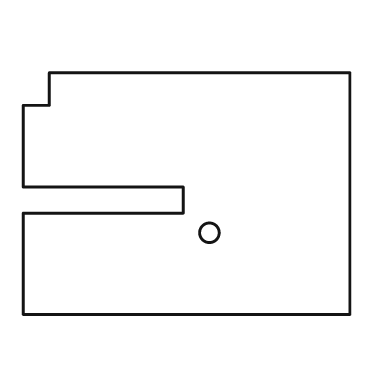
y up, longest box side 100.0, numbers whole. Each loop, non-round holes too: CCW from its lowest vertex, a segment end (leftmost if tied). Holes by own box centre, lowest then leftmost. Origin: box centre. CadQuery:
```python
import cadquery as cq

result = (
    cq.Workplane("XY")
    .moveTo(-50.0, -37.0)
    .lineTo(50.0, -37.0)
    .lineTo(50.0, 37.0)
    .lineTo(-42.0, 37.0)
    .lineTo(-42.0, 27.0)
    .lineTo(-50.0, 27.0)
    .lineTo(-50.0, 2.0)
    .lineTo(-1.0, 2.0)
    .lineTo(-1.0, -6.0)
    .lineTo(-50.0, -6.0)
    .close()
    .moveTo(7.0, -12.0)
    .circle(3.0)
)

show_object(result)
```